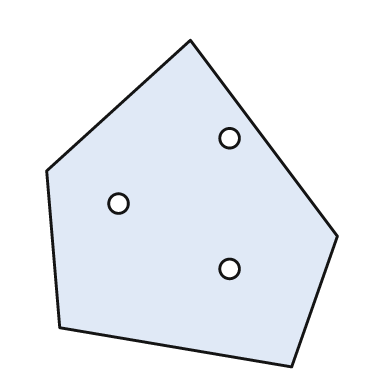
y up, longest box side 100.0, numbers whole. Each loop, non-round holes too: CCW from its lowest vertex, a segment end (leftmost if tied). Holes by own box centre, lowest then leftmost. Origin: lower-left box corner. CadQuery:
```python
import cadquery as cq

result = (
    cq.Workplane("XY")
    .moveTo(75.0, 0.0)
    .lineTo(89.0, 40.0)
    .lineTo(44.0, 100.0)
    .lineTo(0.0, 60.0)
    .lineTo(4.0, 12.0)
    .close()
    .moveTo(56.0, 30.0)
    .circle(3.0)
    .moveTo(22.0, 50.0)
    .circle(3.0)
    .moveTo(56.0, 70.0)
    .circle(3.0)
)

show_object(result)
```